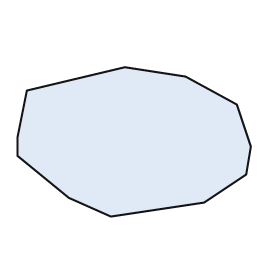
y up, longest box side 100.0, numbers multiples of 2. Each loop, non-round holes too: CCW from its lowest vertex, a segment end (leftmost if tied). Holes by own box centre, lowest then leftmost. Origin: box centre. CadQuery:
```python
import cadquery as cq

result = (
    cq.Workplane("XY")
    .moveTo(-10.0, -32.0)
    .lineTo(30.0, -26.0)
    .lineTo(48.0, -14.0)
    .lineTo(50.0, -2.0)
    .lineTo(44.0, 16.0)
    .lineTo(22.0, 28.0)
    .lineTo(-4.0, 32.0)
    .lineTo(-46.0, 22.0)
    .lineTo(-50.0, 2.0)
    .lineTo(-50.0, -6.0)
    .lineTo(-28.0, -24.0)
    .close()
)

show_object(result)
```